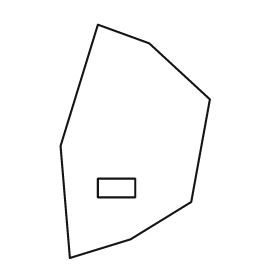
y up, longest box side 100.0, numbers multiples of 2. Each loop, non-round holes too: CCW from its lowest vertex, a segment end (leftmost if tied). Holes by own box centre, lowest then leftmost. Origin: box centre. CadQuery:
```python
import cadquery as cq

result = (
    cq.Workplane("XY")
    .moveTo(-28.0, -50.0)
    .lineTo(-2.0, -42.0)
    .lineTo(24.0, -26.0)
    .lineTo(32.0, 18.0)
    .lineTo(6.0, 42.0)
    .lineTo(-16.0, 50.0)
    .lineTo(-32.0, -2.0)
    .close()
    .moveTo(-16.0, -24.0)
    .lineTo(0.0, -24.0)
    .lineTo(0.0, -16.0)
    .lineTo(-16.0, -16.0)
    .close()
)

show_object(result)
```